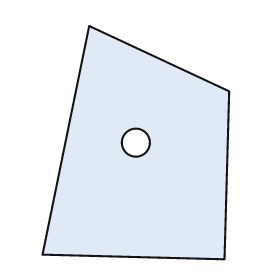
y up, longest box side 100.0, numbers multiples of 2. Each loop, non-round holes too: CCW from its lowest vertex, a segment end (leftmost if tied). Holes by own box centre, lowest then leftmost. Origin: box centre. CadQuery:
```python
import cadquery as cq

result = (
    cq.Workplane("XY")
    .moveTo(38.0, -50.0)
    .lineTo(40.0, 22.0)
    .lineTo(-20.0, 50.0)
    .lineTo(-40.0, -48.0)
    .close()
    .moveTo(0.0, 0.0)
    .circle(6.0)
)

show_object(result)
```